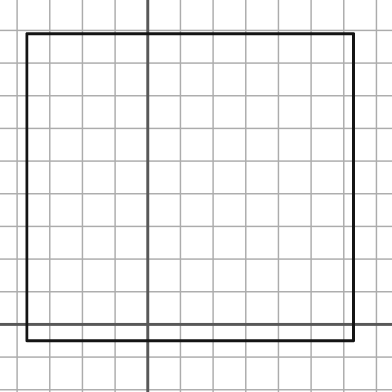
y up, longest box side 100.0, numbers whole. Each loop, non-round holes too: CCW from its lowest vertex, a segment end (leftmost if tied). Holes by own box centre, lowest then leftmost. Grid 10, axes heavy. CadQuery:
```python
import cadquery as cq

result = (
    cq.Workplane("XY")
    .moveTo(-37.0, -5.0)
    .lineTo(63.0, -5.0)
    .lineTo(63.0, 89.0)
    .lineTo(-37.0, 89.0)
    .close()
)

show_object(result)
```